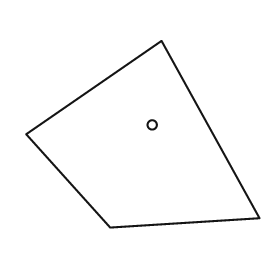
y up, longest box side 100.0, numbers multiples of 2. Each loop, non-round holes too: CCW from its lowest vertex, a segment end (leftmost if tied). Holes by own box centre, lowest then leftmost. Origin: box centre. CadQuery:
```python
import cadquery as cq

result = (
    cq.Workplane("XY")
    .moveTo(-14.0, -40.0)
    .lineTo(50.0, -36.0)
    .lineTo(8.0, 40.0)
    .lineTo(-50.0, 0.0)
    .close()
    .moveTo(4.0, 4.0)
    .circle(2.0)
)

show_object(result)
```